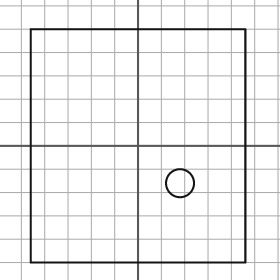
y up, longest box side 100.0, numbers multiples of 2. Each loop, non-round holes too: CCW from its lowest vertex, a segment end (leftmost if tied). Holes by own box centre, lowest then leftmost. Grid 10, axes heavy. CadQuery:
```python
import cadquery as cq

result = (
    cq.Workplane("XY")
    .moveTo(-46.0, -50.0)
    .lineTo(46.0, -50.0)
    .lineTo(46.0, 50.0)
    .lineTo(-46.0, 50.0)
    .close()
    .moveTo(18.0, -16.0)
    .circle(6.0)
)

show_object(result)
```